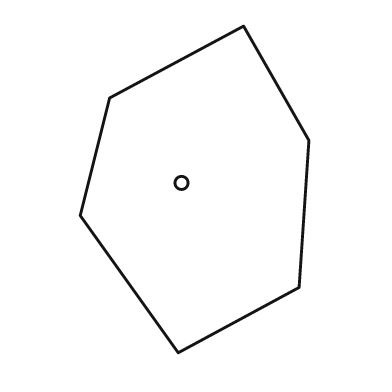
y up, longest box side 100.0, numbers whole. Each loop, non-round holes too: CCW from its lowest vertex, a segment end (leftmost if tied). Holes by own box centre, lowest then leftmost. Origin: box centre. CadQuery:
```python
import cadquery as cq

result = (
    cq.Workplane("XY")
    .moveTo(-5.0, -50.0)
    .lineTo(32.0, -30.0)
    .lineTo(35.0, 15.0)
    .lineTo(15.0, 50.0)
    .lineTo(-26.0, 28.0)
    .lineTo(-35.0, -8.0)
    .close()
    .moveTo(-4.0, 2.0)
    .circle(2.0)
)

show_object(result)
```